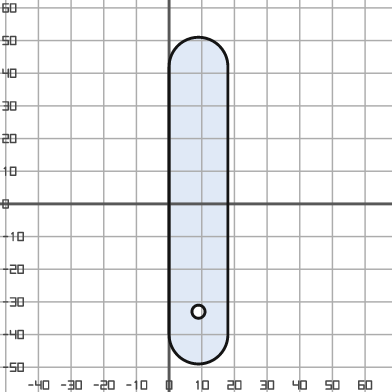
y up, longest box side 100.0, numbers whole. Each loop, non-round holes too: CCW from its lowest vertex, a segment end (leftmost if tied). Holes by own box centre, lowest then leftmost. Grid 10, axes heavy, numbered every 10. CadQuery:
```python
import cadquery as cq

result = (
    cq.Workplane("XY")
    .moveTo(0.0, -40.0)
    .threePointArc((9.0, -49.0), (18.0, -40.0))
    .lineTo(18.0, 42.0)
    .threePointArc((9.0, 51.0), (0.0, 42.0))
    .close()
    .moveTo(9.0, -33.0)
    .circle(2.0)
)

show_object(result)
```